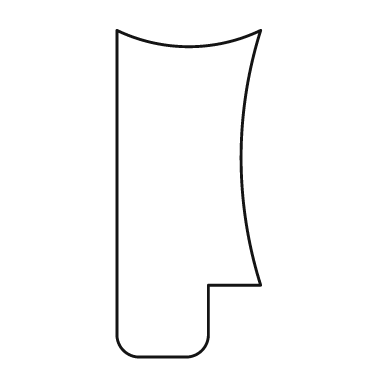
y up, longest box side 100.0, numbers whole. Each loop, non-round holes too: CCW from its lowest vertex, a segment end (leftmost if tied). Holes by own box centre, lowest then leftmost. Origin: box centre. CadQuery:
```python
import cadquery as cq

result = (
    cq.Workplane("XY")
    .moveTo(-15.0, -50.0)
    .lineTo(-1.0, -50.0)
    .threePointArc((4.0, -48.0), (6.0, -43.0))
    .lineTo(6.0, -28.0)
    .lineTo(22.0, -28.0)
    .threePointArc((16.0, 11.0), (22.0, 50.0))
    .threePointArc((0.0, 45.0), (-22.0, 50.0))
    .lineTo(-22.0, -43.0)
    .threePointArc((-20.0, -48.0), (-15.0, -50.0))
    .close()
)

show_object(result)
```